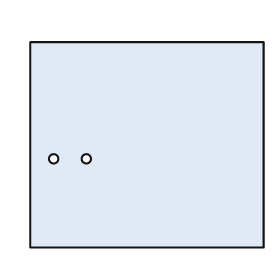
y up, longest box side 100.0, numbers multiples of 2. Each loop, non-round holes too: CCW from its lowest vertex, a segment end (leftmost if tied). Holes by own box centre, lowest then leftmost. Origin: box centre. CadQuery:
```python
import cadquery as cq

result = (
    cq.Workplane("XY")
    .moveTo(-50.0, -44.0)
    .lineTo(50.0, -44.0)
    .lineTo(50.0, 44.0)
    .lineTo(-50.0, 44.0)
    .close()
    .moveTo(-40.0, -6.0)
    .circle(2.0)
    .moveTo(-26.0, -6.0)
    .circle(2.0)
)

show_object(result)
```